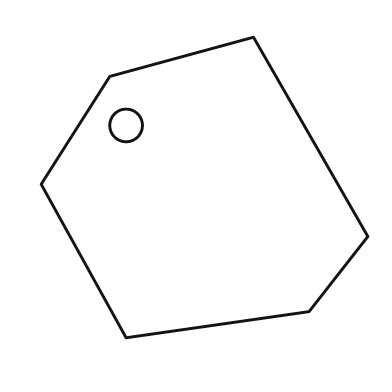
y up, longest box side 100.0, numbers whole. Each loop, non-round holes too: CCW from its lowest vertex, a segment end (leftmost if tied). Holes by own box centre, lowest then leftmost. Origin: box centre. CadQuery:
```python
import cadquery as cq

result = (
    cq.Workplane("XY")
    .moveTo(-24.0, -46.0)
    .lineTo(32.0, -38.0)
    .lineTo(50.0, -15.0)
    .lineTo(15.0, 46.0)
    .lineTo(-29.0, 34.0)
    .lineTo(-50.0, 1.0)
    .close()
    .moveTo(-24.0, 19.0)
    .circle(5.0)
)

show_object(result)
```